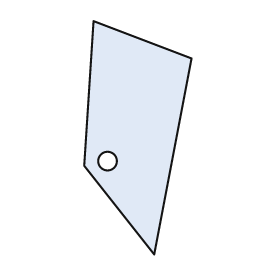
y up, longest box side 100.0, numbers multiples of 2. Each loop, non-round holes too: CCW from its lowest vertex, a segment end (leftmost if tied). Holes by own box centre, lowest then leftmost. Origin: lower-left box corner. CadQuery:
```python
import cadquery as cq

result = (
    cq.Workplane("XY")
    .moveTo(30.0, 0.0)
    .lineTo(46.0, 84.0)
    .lineTo(4.0, 100.0)
    .lineTo(0.0, 38.0)
    .close()
    .moveTo(10.0, 40.0)
    .circle(4.0)
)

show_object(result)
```